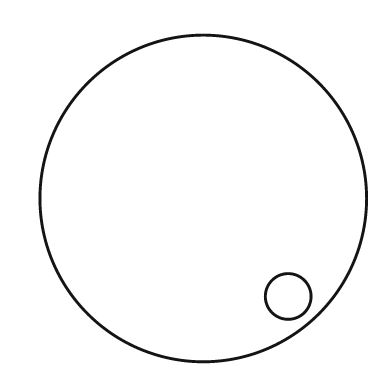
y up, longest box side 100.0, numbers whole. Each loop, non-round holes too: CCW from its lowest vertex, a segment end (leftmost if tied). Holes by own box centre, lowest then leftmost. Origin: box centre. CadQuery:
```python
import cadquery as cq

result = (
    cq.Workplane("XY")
    .moveTo(0.0, 0.0)
    .circle(50.0)
    .moveTo(26.0, -30.0)
    .circle(7.0)
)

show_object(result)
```